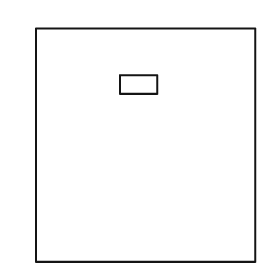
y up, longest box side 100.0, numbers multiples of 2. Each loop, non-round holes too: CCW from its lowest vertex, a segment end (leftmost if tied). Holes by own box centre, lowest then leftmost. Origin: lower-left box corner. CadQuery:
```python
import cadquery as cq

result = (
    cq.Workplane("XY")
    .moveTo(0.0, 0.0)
    .lineTo(94.0, 0.0)
    .lineTo(94.0, 100.0)
    .lineTo(0.0, 100.0)
    .close()
    .moveTo(36.0, 72.0)
    .lineTo(52.0, 72.0)
    .lineTo(52.0, 80.0)
    .lineTo(36.0, 80.0)
    .close()
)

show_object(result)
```